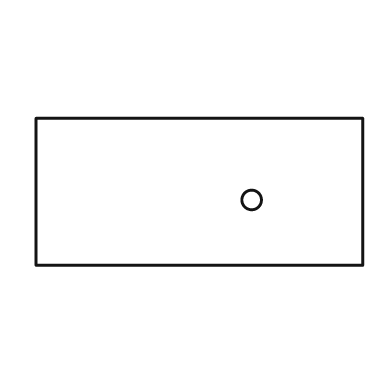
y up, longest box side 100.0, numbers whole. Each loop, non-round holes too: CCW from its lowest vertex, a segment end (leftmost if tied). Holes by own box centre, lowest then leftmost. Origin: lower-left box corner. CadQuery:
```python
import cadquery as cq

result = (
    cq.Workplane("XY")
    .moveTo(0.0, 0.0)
    .lineTo(100.0, 0.0)
    .lineTo(100.0, 45.0)
    .lineTo(0.0, 45.0)
    .close()
    .moveTo(66.0, 20.0)
    .circle(3.0)
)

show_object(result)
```